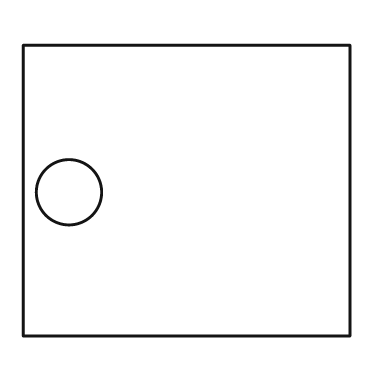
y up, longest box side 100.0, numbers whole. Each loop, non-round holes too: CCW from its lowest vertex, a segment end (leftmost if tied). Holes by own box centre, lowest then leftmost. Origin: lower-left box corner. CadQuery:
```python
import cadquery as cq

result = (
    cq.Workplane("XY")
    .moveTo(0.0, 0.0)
    .lineTo(100.0, 0.0)
    .lineTo(100.0, 89.0)
    .lineTo(0.0, 89.0)
    .close()
    .moveTo(14.0, 44.0)
    .circle(10.0)
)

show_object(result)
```